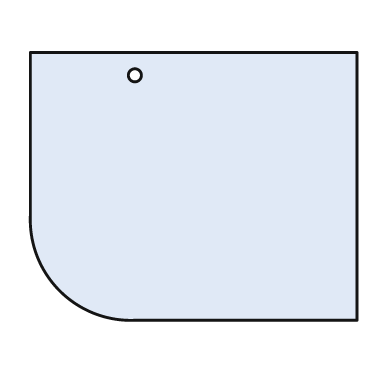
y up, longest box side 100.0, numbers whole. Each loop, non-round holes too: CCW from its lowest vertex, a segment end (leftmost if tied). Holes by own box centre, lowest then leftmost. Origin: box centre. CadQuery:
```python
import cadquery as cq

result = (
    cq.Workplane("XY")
    .moveTo(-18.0, -41.0)
    .lineTo(50.0, -41.0)
    .lineTo(50.0, 41.0)
    .lineTo(-50.0, 41.0)
    .lineTo(-50.0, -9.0)
    .threePointArc((-41.0, -32.0), (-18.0, -41.0))
    .close()
    .moveTo(-18.0, 34.0)
    .circle(2.0)
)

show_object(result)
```